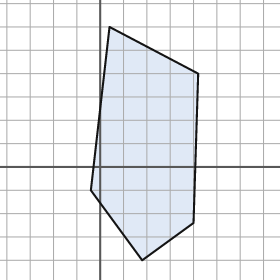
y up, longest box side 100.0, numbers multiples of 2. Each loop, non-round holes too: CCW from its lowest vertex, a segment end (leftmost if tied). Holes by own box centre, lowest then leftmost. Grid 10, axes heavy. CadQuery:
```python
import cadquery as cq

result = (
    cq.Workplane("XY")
    .moveTo(18.0, -40.0)
    .lineTo(40.0, -24.0)
    .lineTo(42.0, 40.0)
    .lineTo(4.0, 60.0)
    .lineTo(-4.0, -10.0)
    .close()
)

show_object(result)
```